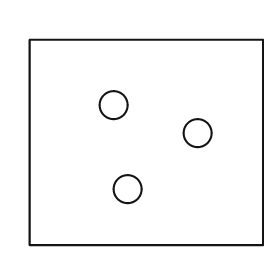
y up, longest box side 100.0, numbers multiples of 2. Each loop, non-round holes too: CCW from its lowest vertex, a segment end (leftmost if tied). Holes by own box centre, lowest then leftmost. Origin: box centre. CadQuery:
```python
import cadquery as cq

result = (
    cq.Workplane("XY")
    .moveTo(-50.0, -44.0)
    .lineTo(50.0, -44.0)
    .lineTo(50.0, 44.0)
    .lineTo(-50.0, 44.0)
    .close()
    .moveTo(-8.0, -20.0)
    .circle(6.0)
    .moveTo(22.0, 4.0)
    .circle(6.0)
    .moveTo(-14.0, 16.0)
    .circle(6.0)
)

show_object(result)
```